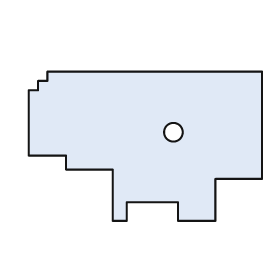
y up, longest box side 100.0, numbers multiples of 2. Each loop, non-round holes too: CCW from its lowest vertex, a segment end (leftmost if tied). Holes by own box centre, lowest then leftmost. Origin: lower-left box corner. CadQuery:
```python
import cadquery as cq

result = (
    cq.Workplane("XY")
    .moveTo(36.0, 0.0)
    .lineTo(42.0, 0.0)
    .lineTo(42.0, 8.0)
    .lineTo(64.0, 8.0)
    .lineTo(64.0, 0.0)
    .lineTo(80.0, 0.0)
    .lineTo(80.0, 18.0)
    .lineTo(100.0, 18.0)
    .lineTo(100.0, 64.0)
    .lineTo(8.0, 64.0)
    .lineTo(8.0, 60.0)
    .lineTo(4.0, 60.0)
    .lineTo(4.0, 56.0)
    .lineTo(0.0, 56.0)
    .lineTo(0.0, 28.0)
    .lineTo(16.0, 28.0)
    .lineTo(16.0, 22.0)
    .lineTo(36.0, 22.0)
    .close()
    .moveTo(62.0, 38.0)
    .circle(4.0)
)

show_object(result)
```